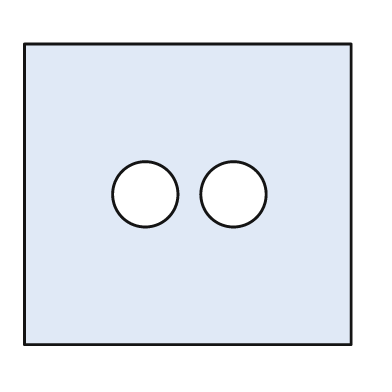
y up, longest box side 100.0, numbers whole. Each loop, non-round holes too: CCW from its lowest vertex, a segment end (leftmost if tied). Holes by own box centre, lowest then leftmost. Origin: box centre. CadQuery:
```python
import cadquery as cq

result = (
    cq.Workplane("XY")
    .moveTo(-50.0, -46.0)
    .lineTo(50.0, -46.0)
    .lineTo(50.0, 46.0)
    .lineTo(-50.0, 46.0)
    .close()
    .moveTo(-13.0, 0.0)
    .circle(10.0)
    .moveTo(14.0, 0.0)
    .circle(10.0)
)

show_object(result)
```